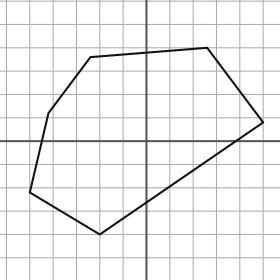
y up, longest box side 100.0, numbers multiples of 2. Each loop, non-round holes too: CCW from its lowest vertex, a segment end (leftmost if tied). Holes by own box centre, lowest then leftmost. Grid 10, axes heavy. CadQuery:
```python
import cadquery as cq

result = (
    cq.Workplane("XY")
    .moveTo(-20.0, -40.0)
    .lineTo(50.0, 8.0)
    .lineTo(26.0, 40.0)
    .lineTo(-24.0, 36.0)
    .lineTo(-42.0, 12.0)
    .lineTo(-50.0, -22.0)
    .close()
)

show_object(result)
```